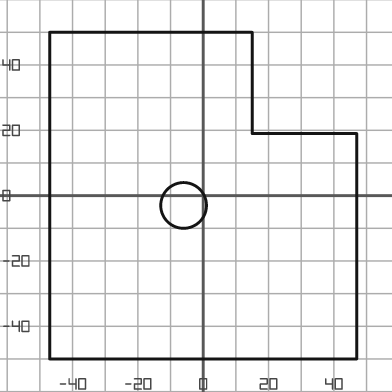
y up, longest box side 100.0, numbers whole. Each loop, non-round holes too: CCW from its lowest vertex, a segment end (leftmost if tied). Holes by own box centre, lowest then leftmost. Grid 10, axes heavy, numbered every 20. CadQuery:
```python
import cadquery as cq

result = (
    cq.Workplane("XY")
    .moveTo(-47.0, -50.0)
    .lineTo(47.0, -50.0)
    .lineTo(47.0, 19.0)
    .lineTo(15.0, 19.0)
    .lineTo(15.0, 50.0)
    .lineTo(-47.0, 50.0)
    .close()
    .moveTo(-6.0, -3.0)
    .circle(7.0)
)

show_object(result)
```